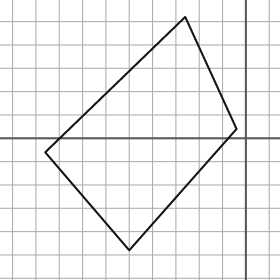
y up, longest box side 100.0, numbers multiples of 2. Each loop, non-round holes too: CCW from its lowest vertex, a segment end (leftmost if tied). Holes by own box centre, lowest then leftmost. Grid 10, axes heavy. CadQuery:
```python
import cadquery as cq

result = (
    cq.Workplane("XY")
    .moveTo(-50.0, -48.0)
    .lineTo(-4.0, 4.0)
    .lineTo(-26.0, 52.0)
    .lineTo(-86.0, -6.0)
    .close()
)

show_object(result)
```